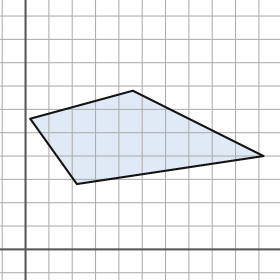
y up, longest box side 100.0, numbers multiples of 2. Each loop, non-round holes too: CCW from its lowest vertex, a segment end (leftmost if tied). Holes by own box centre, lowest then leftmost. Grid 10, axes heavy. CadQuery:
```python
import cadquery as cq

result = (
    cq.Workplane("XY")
    .moveTo(22.0, 28.0)
    .lineTo(102.0, 40.0)
    .lineTo(46.0, 68.0)
    .lineTo(2.0, 56.0)
    .close()
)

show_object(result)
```